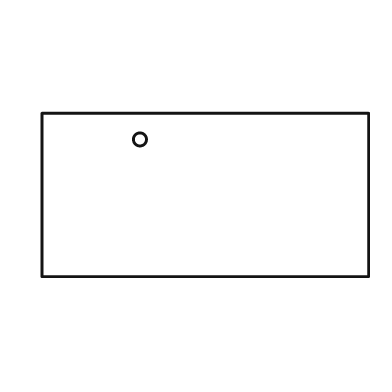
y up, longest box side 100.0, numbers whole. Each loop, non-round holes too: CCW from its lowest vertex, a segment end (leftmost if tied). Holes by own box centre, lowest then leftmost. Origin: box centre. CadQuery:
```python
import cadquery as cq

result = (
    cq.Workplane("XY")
    .moveTo(-50.0, -25.0)
    .lineTo(50.0, -25.0)
    .lineTo(50.0, 25.0)
    .lineTo(-50.0, 25.0)
    .close()
    .moveTo(-20.0, 17.0)
    .circle(2.0)
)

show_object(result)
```